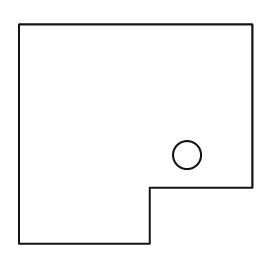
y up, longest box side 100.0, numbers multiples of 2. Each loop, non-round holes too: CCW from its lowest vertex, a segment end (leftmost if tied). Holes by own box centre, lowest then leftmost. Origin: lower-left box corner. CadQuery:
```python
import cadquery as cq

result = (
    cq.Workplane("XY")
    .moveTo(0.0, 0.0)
    .lineTo(56.0, 0.0)
    .lineTo(56.0, 24.0)
    .lineTo(100.0, 24.0)
    .lineTo(100.0, 94.0)
    .lineTo(0.0, 94.0)
    .close()
    .moveTo(72.0, 38.0)
    .circle(6.0)
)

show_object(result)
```